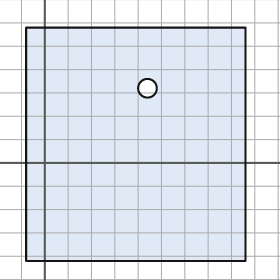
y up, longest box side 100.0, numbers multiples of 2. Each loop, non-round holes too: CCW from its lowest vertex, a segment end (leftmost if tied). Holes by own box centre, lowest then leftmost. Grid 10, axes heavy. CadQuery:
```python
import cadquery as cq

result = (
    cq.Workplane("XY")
    .moveTo(-8.0, -42.0)
    .lineTo(86.0, -42.0)
    .lineTo(86.0, 58.0)
    .lineTo(-8.0, 58.0)
    .close()
    .moveTo(44.0, 32.0)
    .circle(4.0)
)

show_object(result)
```